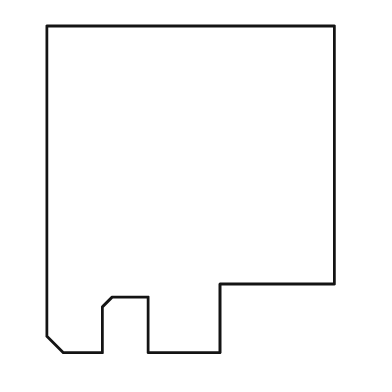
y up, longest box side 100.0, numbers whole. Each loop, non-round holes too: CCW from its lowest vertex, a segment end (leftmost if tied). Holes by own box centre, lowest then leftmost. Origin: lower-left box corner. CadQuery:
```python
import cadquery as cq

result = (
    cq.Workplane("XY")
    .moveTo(5.0, 0.0)
    .lineTo(17.0, 0.0)
    .lineTo(17.0, 14.0)
    .lineTo(20.0, 17.0)
    .lineTo(31.0, 17.0)
    .lineTo(31.0, 0.0)
    .lineTo(53.0, 0.0)
    .lineTo(53.0, 21.0)
    .lineTo(88.0, 21.0)
    .lineTo(88.0, 100.0)
    .lineTo(0.0, 100.0)
    .lineTo(0.0, 5.0)
    .close()
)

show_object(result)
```